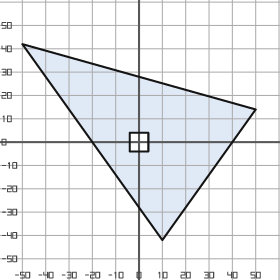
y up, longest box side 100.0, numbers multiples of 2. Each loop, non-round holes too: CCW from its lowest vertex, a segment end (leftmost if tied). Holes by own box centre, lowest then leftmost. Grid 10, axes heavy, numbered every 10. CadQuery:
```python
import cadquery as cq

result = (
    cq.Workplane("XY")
    .moveTo(10.0, -42.0)
    .lineTo(50.0, 14.0)
    .lineTo(-50.0, 42.0)
    .close()
    .moveTo(-4.0, -4.0)
    .lineTo(4.0, -4.0)
    .lineTo(4.0, 4.0)
    .lineTo(-4.0, 4.0)
    .close()
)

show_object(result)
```